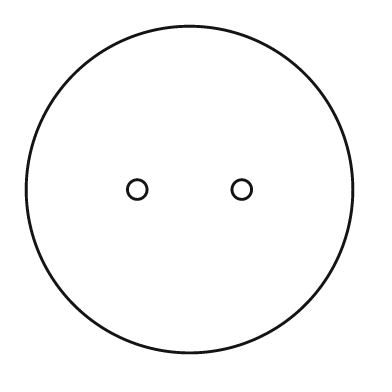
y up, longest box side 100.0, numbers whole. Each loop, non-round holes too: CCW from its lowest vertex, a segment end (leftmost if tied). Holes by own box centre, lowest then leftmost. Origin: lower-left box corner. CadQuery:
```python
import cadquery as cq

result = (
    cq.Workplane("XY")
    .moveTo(50.0, 50.0)
    .circle(50.0)
    .moveTo(34.0, 50.0)
    .circle(3.0)
    .moveTo(66.0, 50.0)
    .circle(3.0)
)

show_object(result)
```